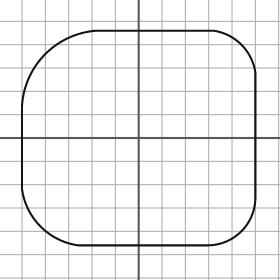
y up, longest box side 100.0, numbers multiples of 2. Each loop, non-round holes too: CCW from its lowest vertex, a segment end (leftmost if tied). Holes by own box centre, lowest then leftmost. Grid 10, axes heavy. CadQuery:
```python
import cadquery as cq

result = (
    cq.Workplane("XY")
    .moveTo(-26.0, -46.0)
    .lineTo(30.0, -46.0)
    .threePointArc((44.0, -40.0), (50.0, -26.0))
    .lineTo(50.0, 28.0)
    .threePointArc((44.0, 40.0), (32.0, 46.0))
    .lineTo(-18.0, 46.0)
    .threePointArc((-40.0, 36.0), (-50.0, 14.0))
    .lineTo(-50.0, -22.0)
    .threePointArc((-42.0, -38.0), (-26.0, -46.0))
    .close()
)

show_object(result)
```